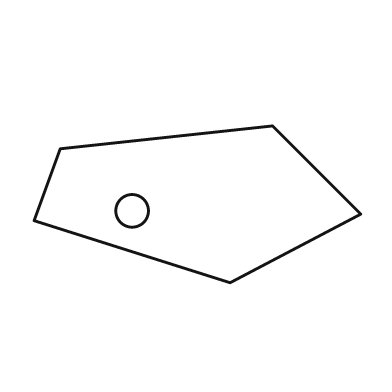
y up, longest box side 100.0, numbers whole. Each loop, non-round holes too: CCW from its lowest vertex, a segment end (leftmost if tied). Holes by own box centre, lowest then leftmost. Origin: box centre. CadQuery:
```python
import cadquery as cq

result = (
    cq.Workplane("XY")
    .moveTo(10.0, -24.0)
    .lineTo(50.0, -3.0)
    .lineTo(23.0, 24.0)
    .lineTo(-42.0, 17.0)
    .lineTo(-50.0, -5.0)
    .close()
    .moveTo(-20.0, -2.0)
    .circle(5.0)
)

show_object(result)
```